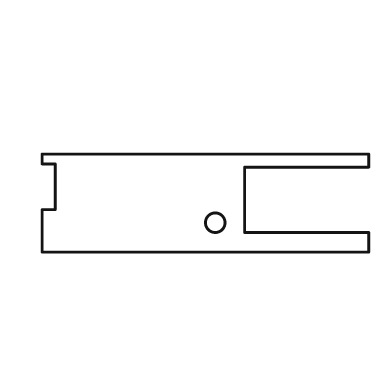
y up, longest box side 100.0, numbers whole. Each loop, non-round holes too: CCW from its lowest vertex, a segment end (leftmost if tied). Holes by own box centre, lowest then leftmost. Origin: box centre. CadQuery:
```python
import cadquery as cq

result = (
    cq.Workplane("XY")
    .moveTo(-50.0, -15.0)
    .lineTo(50.0, -15.0)
    .lineTo(50.0, -9.0)
    .lineTo(12.0, -9.0)
    .lineTo(12.0, 11.0)
    .lineTo(50.0, 11.0)
    .lineTo(50.0, 15.0)
    .lineTo(-50.0, 15.0)
    .lineTo(-50.0, 12.0)
    .lineTo(-46.0, 12.0)
    .lineTo(-46.0, -2.0)
    .lineTo(-50.0, -2.0)
    .close()
    .moveTo(3.0, -6.0)
    .circle(3.0)
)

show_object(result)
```